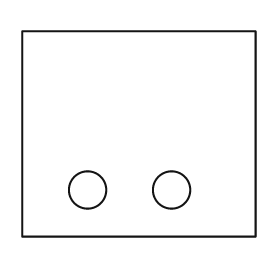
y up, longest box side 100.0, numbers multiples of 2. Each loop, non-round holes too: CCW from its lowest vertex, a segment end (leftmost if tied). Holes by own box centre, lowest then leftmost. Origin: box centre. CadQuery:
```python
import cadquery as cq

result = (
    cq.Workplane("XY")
    .moveTo(-50.0, -44.0)
    .lineTo(50.0, -44.0)
    .lineTo(50.0, 44.0)
    .lineTo(-50.0, 44.0)
    .close()
    .moveTo(-22.0, -24.0)
    .circle(8.0)
    .moveTo(14.0, -24.0)
    .circle(8.0)
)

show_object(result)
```